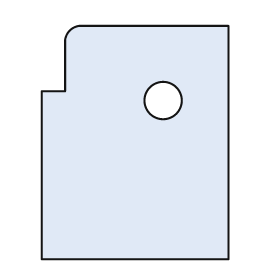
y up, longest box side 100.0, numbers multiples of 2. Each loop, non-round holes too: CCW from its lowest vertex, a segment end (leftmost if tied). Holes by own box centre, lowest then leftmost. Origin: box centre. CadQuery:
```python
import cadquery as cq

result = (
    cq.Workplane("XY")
    .moveTo(-40.0, -50.0)
    .lineTo(40.0, -50.0)
    .lineTo(40.0, 50.0)
    .lineTo(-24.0, 50.0)
    .threePointArc((-28.0, 48.0), (-30.0, 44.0))
    .lineTo(-30.0, 22.0)
    .lineTo(-40.0, 22.0)
    .close()
    .moveTo(12.0, 18.0)
    .circle(8.0)
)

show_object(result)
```